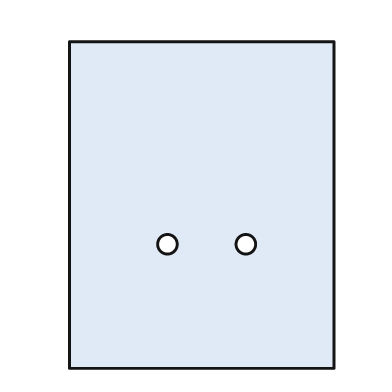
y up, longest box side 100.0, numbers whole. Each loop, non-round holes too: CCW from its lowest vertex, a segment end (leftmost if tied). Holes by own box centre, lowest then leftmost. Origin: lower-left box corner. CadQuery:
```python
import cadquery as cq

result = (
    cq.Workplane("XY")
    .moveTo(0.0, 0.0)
    .lineTo(81.0, 0.0)
    .lineTo(81.0, 100.0)
    .lineTo(0.0, 100.0)
    .close()
    .moveTo(30.0, 38.0)
    .circle(3.0)
    .moveTo(54.0, 38.0)
    .circle(3.0)
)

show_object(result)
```